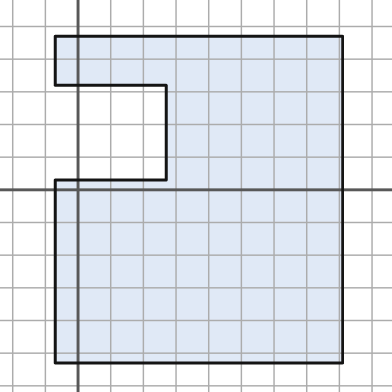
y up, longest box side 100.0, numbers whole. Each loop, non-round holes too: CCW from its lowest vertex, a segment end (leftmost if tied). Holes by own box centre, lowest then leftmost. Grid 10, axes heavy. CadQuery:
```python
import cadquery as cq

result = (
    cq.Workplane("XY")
    .moveTo(-7.0, -53.0)
    .lineTo(81.0, -53.0)
    .lineTo(81.0, 47.0)
    .lineTo(-7.0, 47.0)
    .lineTo(-7.0, 32.0)
    .lineTo(27.0, 32.0)
    .lineTo(27.0, 3.0)
    .lineTo(-7.0, 3.0)
    .close()
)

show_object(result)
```